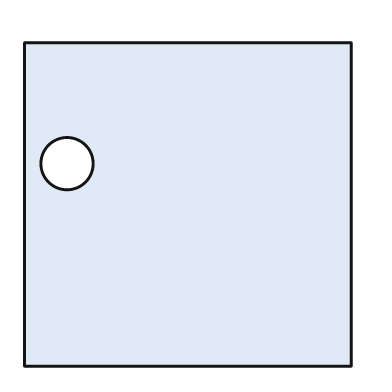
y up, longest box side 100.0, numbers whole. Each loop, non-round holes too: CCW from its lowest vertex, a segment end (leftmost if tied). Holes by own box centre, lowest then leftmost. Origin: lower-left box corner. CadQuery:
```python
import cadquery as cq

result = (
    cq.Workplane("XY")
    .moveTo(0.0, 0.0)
    .lineTo(100.0, 0.0)
    .lineTo(100.0, 99.0)
    .lineTo(0.0, 99.0)
    .close()
    .moveTo(13.0, 62.0)
    .circle(8.0)
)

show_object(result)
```